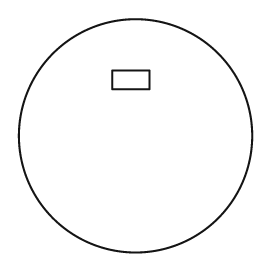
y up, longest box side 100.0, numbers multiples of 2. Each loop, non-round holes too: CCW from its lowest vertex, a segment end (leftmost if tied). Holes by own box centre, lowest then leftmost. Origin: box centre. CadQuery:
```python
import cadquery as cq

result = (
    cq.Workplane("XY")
    .moveTo(0.0, 0.0)
    .circle(50.0)
    .moveTo(-10.0, 20.0)
    .lineTo(6.0, 20.0)
    .lineTo(6.0, 28.0)
    .lineTo(-10.0, 28.0)
    .close()
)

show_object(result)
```